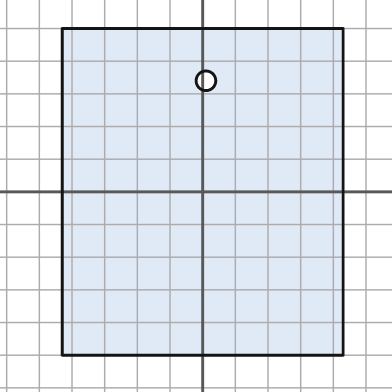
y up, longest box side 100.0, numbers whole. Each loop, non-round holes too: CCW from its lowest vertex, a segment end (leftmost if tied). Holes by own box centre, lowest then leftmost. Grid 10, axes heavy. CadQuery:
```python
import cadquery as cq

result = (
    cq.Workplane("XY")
    .moveTo(-43.0, -50.0)
    .lineTo(43.0, -50.0)
    .lineTo(43.0, 50.0)
    .lineTo(-43.0, 50.0)
    .close()
    .moveTo(1.0, 34.0)
    .circle(3.0)
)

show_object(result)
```